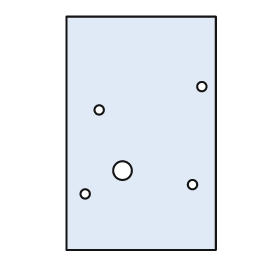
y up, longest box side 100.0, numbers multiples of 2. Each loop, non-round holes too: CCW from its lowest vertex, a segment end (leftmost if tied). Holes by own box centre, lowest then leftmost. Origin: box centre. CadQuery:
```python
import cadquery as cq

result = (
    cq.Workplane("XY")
    .moveTo(-32.0, -50.0)
    .lineTo(32.0, -50.0)
    .lineTo(32.0, 50.0)
    .lineTo(-32.0, 50.0)
    .close()
    .moveTo(-24.0, -26.0)
    .circle(2.0)
    .moveTo(22.0, -22.0)
    .circle(2.0)
    .moveTo(-8.0, -16.0)
    .circle(4.0)
    .moveTo(-18.0, 10.0)
    .circle(2.0)
    .moveTo(26.0, 20.0)
    .circle(2.0)
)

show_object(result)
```